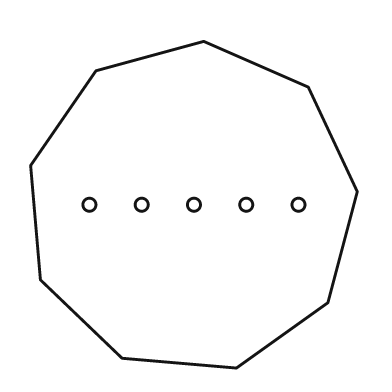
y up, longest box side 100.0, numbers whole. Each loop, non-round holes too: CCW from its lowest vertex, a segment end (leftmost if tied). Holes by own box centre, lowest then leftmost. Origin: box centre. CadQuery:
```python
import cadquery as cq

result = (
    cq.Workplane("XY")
    .moveTo(13.0, -50.0)
    .lineTo(41.0, -30.0)
    .lineTo(50.0, 4.0)
    .lineTo(35.0, 36.0)
    .lineTo(3.0, 50.0)
    .lineTo(-30.0, 41.0)
    .lineTo(-50.0, 12.0)
    .lineTo(-47.0, -23.0)
    .lineTo(-22.0, -47.0)
    .close()
    .moveTo(-32.0, 0.0)
    .circle(2.0)
    .moveTo(-16.0, 0.0)
    .circle(2.0)
    .moveTo(0.0, 0.0)
    .circle(2.0)
    .moveTo(16.0, 0.0)
    .circle(2.0)
    .moveTo(32.0, 0.0)
    .circle(2.0)
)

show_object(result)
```